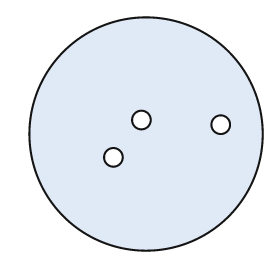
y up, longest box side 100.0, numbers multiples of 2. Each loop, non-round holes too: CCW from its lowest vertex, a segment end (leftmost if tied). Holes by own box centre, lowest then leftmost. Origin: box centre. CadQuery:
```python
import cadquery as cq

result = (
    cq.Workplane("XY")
    .moveTo(0.0, 0.0)
    .circle(50.0)
    .moveTo(-14.0, -10.0)
    .circle(4.0)
    .moveTo(32.0, 4.0)
    .circle(4.0)
    .moveTo(-2.0, 6.0)
    .circle(4.0)
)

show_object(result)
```